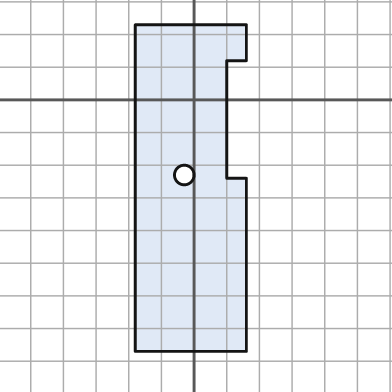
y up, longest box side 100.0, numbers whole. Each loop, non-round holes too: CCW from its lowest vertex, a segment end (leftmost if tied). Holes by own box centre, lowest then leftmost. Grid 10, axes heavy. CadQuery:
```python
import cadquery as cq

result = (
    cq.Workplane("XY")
    .moveTo(-18.0, -77.0)
    .lineTo(16.0, -77.0)
    .lineTo(16.0, -24.0)
    .lineTo(10.0, -24.0)
    .lineTo(10.0, 12.0)
    .lineTo(16.0, 12.0)
    .lineTo(16.0, 23.0)
    .lineTo(-18.0, 23.0)
    .close()
    .moveTo(-3.0, -23.0)
    .circle(3.0)
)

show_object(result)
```